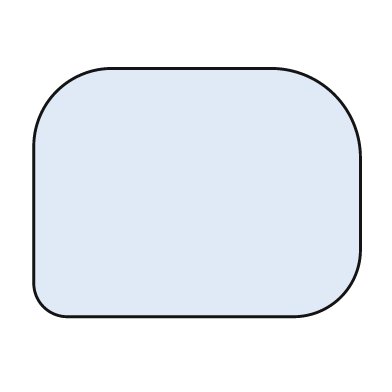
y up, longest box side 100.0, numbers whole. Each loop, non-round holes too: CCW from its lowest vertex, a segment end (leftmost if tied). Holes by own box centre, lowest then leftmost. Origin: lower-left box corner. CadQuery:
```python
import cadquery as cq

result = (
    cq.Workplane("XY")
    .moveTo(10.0, 0.0)
    .lineTo(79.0, 0.0)
    .threePointArc((94.0, 6.0), (100.0, 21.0))
    .lineTo(100.0, 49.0)
    .threePointArc((92.0, 68.0), (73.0, 76.0))
    .lineTo(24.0, 76.0)
    .threePointArc((7.0, 69.0), (0.0, 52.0))
    .lineTo(0.0, 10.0)
    .threePointArc((3.0, 3.0), (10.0, 0.0))
    .close()
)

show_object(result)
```